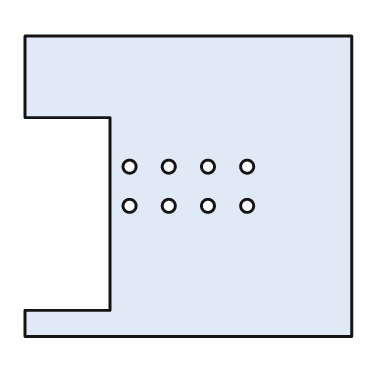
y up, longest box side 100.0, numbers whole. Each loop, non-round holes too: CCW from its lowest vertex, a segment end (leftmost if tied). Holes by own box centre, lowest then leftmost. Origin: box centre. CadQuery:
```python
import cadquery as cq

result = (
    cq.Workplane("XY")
    .moveTo(-50.0, -46.0)
    .lineTo(50.0, -46.0)
    .lineTo(50.0, 46.0)
    .lineTo(-50.0, 46.0)
    .lineTo(-50.0, 21.0)
    .lineTo(-24.0, 21.0)
    .lineTo(-24.0, -38.0)
    .lineTo(-50.0, -38.0)
    .close()
    .moveTo(-18.0, -6.0)
    .circle(2.0)
    .moveTo(-6.0, -6.0)
    .circle(2.0)
    .moveTo(6.0, -6.0)
    .circle(2.0)
    .moveTo(18.0, -6.0)
    .circle(2.0)
    .moveTo(-18.0, 6.0)
    .circle(2.0)
    .moveTo(-6.0, 6.0)
    .circle(2.0)
    .moveTo(6.0, 6.0)
    .circle(2.0)
    .moveTo(18.0, 6.0)
    .circle(2.0)
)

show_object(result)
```